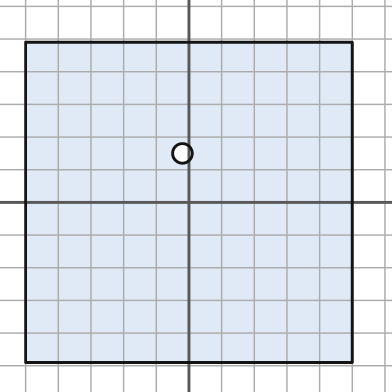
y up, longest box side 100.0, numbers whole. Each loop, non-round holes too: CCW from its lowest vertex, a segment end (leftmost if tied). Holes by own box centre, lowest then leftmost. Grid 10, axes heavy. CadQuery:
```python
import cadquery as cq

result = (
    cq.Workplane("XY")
    .moveTo(-50.0, -49.0)
    .lineTo(50.0, -49.0)
    .lineTo(50.0, 49.0)
    .lineTo(-50.0, 49.0)
    .close()
    .moveTo(-2.0, 15.0)
    .circle(3.0)
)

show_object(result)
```